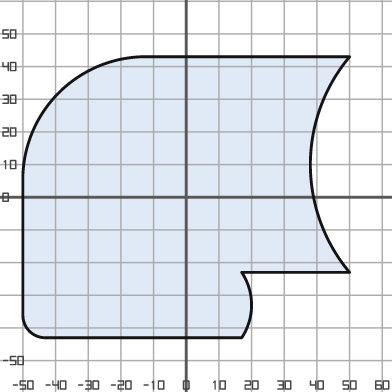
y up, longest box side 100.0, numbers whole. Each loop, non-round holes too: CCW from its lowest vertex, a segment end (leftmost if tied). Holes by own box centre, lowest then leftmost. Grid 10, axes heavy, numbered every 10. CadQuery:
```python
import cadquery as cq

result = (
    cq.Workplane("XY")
    .moveTo(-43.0, -43.0)
    .lineTo(17.0, -43.0)
    .threePointArc((20.0, -33.0), (17.0, -23.0))
    .lineTo(50.0, -23.0)
    .threePointArc((38.0, 10.0), (50.0, 43.0))
    .lineTo(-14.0, 43.0)
    .threePointArc((-39.0, 32.0), (-50.0, 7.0))
    .lineTo(-50.0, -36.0)
    .threePointArc((-48.0, -41.0), (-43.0, -43.0))
    .close()
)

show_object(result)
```